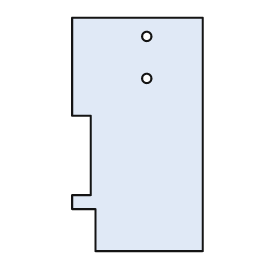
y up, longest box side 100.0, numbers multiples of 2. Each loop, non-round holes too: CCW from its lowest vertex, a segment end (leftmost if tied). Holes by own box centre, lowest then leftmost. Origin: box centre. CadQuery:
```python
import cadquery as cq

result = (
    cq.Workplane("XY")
    .moveTo(-18.0, -50.0)
    .lineTo(28.0, -50.0)
    .lineTo(28.0, 50.0)
    .lineTo(-28.0, 50.0)
    .lineTo(-28.0, 8.0)
    .lineTo(-20.0, 8.0)
    .lineTo(-20.0, -26.0)
    .lineTo(-28.0, -26.0)
    .lineTo(-28.0, -32.0)
    .lineTo(-18.0, -32.0)
    .close()
    .moveTo(4.0, 24.0)
    .circle(2.0)
    .moveTo(4.0, 42.0)
    .circle(2.0)
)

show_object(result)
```